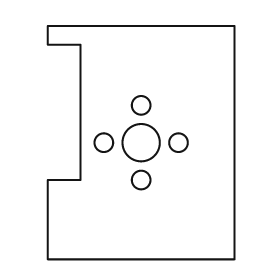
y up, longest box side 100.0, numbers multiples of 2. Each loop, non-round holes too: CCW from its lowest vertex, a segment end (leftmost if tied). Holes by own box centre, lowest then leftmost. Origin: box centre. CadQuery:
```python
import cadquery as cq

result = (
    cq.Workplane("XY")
    .moveTo(-40.0, -50.0)
    .lineTo(40.0, -50.0)
    .lineTo(40.0, 50.0)
    .lineTo(-40.0, 50.0)
    .lineTo(-40.0, 42.0)
    .lineTo(-26.0, 42.0)
    .lineTo(-26.0, -16.0)
    .lineTo(-40.0, -16.0)
    .close()
    .moveTo(0.0, -16.0)
    .circle(4.0)
    .moveTo(-16.0, 0.0)
    .circle(4.0)
    .moveTo(0.0, 0.0)
    .circle(8.0)
    .moveTo(16.0, 0.0)
    .circle(4.0)
    .moveTo(0.0, 16.0)
    .circle(4.0)
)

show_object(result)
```